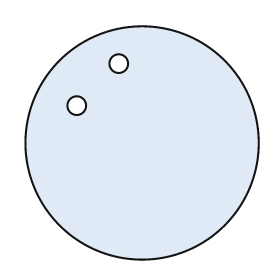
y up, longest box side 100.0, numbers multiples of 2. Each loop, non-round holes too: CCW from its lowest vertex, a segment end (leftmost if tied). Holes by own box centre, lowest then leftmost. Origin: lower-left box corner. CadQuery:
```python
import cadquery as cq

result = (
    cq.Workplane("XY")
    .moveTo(50.0, 50.0)
    .circle(50.0)
    .moveTo(22.0, 66.0)
    .circle(4.0)
    .moveTo(40.0, 84.0)
    .circle(4.0)
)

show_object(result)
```